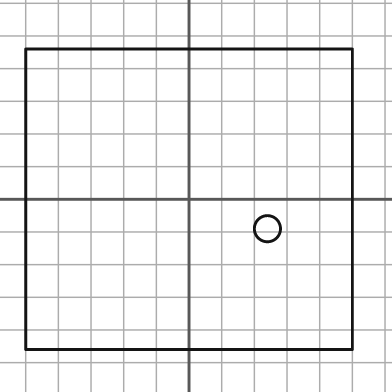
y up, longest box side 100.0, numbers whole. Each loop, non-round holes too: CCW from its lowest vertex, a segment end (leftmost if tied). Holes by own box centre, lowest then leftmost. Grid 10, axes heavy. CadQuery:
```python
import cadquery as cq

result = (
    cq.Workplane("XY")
    .moveTo(-50.0, -46.0)
    .lineTo(50.0, -46.0)
    .lineTo(50.0, 46.0)
    .lineTo(-50.0, 46.0)
    .close()
    .moveTo(24.0, -9.0)
    .circle(4.0)
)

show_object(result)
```